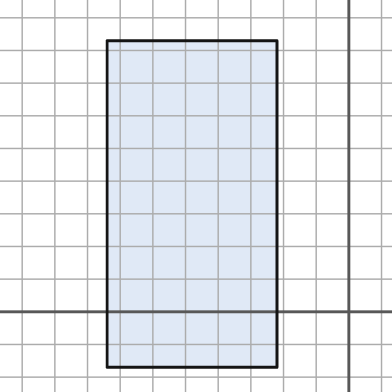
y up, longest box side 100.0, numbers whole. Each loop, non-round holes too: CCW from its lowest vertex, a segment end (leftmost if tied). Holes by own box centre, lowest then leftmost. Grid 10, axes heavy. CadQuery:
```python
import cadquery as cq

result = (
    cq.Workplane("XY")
    .moveTo(-74.0, -17.0)
    .lineTo(-22.0, -17.0)
    .lineTo(-22.0, 83.0)
    .lineTo(-74.0, 83.0)
    .close()
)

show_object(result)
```